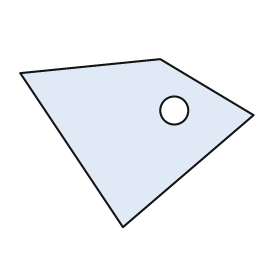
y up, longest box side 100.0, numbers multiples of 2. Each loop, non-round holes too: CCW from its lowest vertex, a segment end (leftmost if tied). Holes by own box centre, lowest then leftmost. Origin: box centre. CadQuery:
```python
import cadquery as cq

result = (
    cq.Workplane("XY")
    .moveTo(-6.0, -36.0)
    .lineTo(50.0, 12.0)
    .lineTo(10.0, 36.0)
    .lineTo(-50.0, 30.0)
    .close()
    .moveTo(16.0, 14.0)
    .circle(6.0)
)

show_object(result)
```